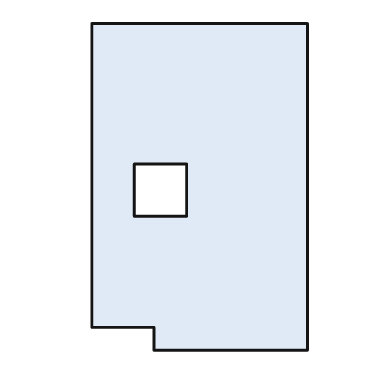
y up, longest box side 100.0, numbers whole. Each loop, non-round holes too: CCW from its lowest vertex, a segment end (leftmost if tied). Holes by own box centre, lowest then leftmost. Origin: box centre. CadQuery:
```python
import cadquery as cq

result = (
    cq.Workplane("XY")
    .moveTo(-14.0, -50.0)
    .lineTo(33.0, -50.0)
    .lineTo(33.0, 50.0)
    .lineTo(-33.0, 50.0)
    .lineTo(-33.0, -43.0)
    .lineTo(-14.0, -43.0)
    .close()
    .moveTo(-20.0, -9.0)
    .lineTo(-4.0, -9.0)
    .lineTo(-4.0, 7.0)
    .lineTo(-20.0, 7.0)
    .close()
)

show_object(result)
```